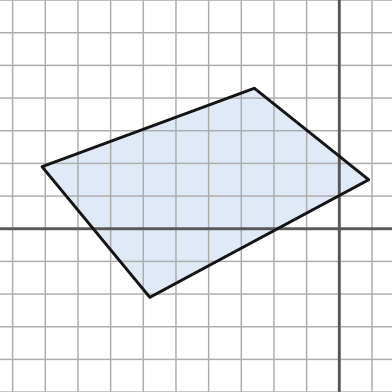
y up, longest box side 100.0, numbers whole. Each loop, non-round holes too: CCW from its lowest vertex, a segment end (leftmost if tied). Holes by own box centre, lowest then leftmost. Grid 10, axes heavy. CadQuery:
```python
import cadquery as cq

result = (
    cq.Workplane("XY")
    .moveTo(-58.0, -21.0)
    .lineTo(9.0, 15.0)
    .lineTo(-26.0, 43.0)
    .lineTo(-91.0, 19.0)
    .close()
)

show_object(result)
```